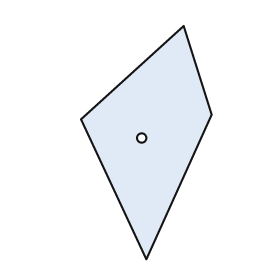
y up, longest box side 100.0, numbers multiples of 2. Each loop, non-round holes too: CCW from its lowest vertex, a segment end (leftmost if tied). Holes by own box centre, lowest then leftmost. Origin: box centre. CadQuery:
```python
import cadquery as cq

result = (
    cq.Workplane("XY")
    .moveTo(0.0, -50.0)
    .lineTo(28.0, 12.0)
    .lineTo(16.0, 50.0)
    .lineTo(-28.0, 10.0)
    .close()
    .moveTo(-2.0, 2.0)
    .circle(2.0)
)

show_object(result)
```